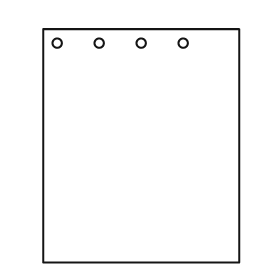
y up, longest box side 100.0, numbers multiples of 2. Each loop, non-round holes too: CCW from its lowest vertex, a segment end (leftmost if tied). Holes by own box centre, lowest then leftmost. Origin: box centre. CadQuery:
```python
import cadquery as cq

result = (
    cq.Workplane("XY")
    .moveTo(-42.0, -50.0)
    .lineTo(42.0, -50.0)
    .lineTo(42.0, 50.0)
    .lineTo(-42.0, 50.0)
    .close()
    .moveTo(-36.0, 44.0)
    .circle(2.0)
    .moveTo(-18.0, 44.0)
    .circle(2.0)
    .moveTo(0.0, 44.0)
    .circle(2.0)
    .moveTo(18.0, 44.0)
    .circle(2.0)
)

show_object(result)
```